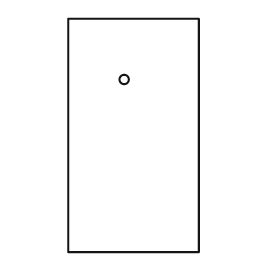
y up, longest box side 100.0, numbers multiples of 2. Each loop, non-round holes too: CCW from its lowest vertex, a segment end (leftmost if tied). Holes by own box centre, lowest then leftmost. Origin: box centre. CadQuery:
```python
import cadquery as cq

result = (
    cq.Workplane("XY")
    .moveTo(-28.0, -50.0)
    .lineTo(28.0, -50.0)
    .lineTo(28.0, 50.0)
    .lineTo(-28.0, 50.0)
    .close()
    .moveTo(-4.0, 24.0)
    .circle(2.0)
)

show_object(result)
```